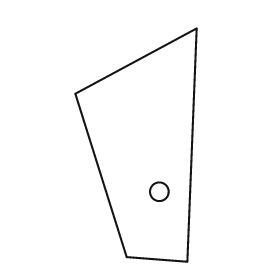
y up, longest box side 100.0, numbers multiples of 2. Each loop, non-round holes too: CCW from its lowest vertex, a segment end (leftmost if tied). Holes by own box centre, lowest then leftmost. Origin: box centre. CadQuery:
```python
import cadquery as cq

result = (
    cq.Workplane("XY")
    .moveTo(22.0, -50.0)
    .lineTo(26.0, 50.0)
    .lineTo(-26.0, 22.0)
    .lineTo(-4.0, -48.0)
    .close()
    .moveTo(10.0, -20.0)
    .circle(4.0)
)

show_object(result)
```